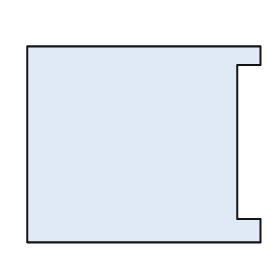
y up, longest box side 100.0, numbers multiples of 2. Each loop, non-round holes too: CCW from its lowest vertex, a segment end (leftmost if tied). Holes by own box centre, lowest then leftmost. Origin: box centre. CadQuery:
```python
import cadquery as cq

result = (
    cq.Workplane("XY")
    .moveTo(-50.0, -42.0)
    .lineTo(50.0, -42.0)
    .lineTo(50.0, -32.0)
    .lineTo(40.0, -32.0)
    .lineTo(40.0, 34.0)
    .lineTo(50.0, 34.0)
    .lineTo(50.0, 42.0)
    .lineTo(-50.0, 42.0)
    .close()
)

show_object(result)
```